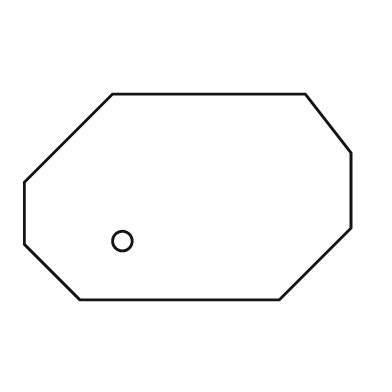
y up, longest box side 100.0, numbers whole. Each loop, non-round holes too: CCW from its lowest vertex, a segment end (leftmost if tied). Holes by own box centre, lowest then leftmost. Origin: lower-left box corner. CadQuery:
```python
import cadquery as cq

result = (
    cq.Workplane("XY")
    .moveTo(17.0, 0.0)
    .lineTo(78.0, 0.0)
    .lineTo(100.0, 22.0)
    .lineTo(100.0, 45.0)
    .lineTo(86.0, 63.0)
    .lineTo(27.0, 63.0)
    .lineTo(0.0, 36.0)
    .lineTo(0.0, 17.0)
    .close()
    .moveTo(30.0, 18.0)
    .circle(3.0)
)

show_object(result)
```